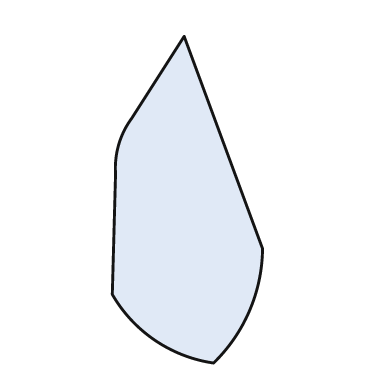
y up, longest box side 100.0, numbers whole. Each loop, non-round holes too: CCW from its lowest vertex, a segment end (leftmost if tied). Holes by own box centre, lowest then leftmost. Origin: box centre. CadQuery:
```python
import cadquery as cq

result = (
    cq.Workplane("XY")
    .moveTo(8.0, -50.0)
    .threePointArc((19.0, -34.0), (23.0, -15.0))
    .lineTo(-1.0, 50.0)
    .lineTo(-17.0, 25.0)
    .threePointArc((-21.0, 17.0), (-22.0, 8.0))
    .lineTo(-23.0, -29.0)
    .threePointArc((-10.0, -43.0), (8.0, -50.0))
    .close()
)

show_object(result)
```